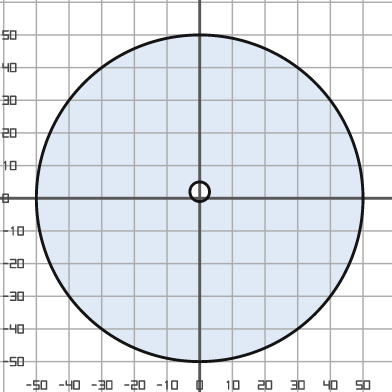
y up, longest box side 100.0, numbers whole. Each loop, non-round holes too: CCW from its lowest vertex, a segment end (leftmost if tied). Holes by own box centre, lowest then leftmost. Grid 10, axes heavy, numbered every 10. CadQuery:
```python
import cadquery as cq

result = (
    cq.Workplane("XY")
    .moveTo(0.0, 0.0)
    .circle(50.0)
    .moveTo(0.0, 2.0)
    .circle(3.0)
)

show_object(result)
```